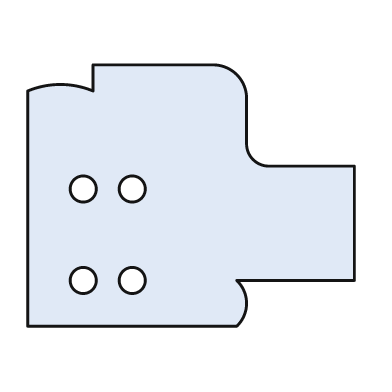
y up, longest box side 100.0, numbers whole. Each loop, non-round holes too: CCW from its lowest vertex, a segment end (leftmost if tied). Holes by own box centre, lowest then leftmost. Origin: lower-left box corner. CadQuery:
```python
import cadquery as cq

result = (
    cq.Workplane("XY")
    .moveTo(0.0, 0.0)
    .lineTo(64.0, 0.0)
    .threePointArc((67.0, 7.0), (64.0, 14.0))
    .lineTo(100.0, 14.0)
    .lineTo(100.0, 49.0)
    .lineTo(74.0, 49.0)
    .threePointArc((69.0, 51.0), (67.0, 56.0))
    .lineTo(67.0, 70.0)
    .threePointArc((64.0, 77.0), (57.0, 80.0))
    .lineTo(20.0, 80.0)
    .lineTo(20.0, 72.0)
    .threePointArc((10.0, 74.0), (0.0, 72.0))
    .close()
    .moveTo(17.0, 14.0)
    .circle(4.0)
    .moveTo(32.0, 14.0)
    .circle(4.0)
    .moveTo(17.0, 42.0)
    .circle(4.0)
    .moveTo(32.0, 42.0)
    .circle(4.0)
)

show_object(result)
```